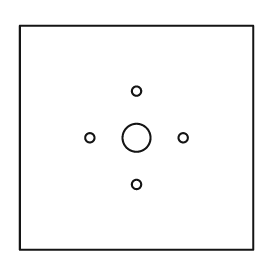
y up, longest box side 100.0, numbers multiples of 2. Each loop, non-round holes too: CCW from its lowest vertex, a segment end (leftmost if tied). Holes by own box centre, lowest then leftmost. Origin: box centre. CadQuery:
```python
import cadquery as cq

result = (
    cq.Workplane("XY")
    .moveTo(-50.0, -48.0)
    .lineTo(50.0, -48.0)
    .lineTo(50.0, 48.0)
    .lineTo(-50.0, 48.0)
    .close()
    .moveTo(0.0, -20.0)
    .circle(2.0)
    .moveTo(-20.0, 0.0)
    .circle(2.0)
    .moveTo(0.0, 0.0)
    .circle(6.0)
    .moveTo(20.0, 0.0)
    .circle(2.0)
    .moveTo(0.0, 20.0)
    .circle(2.0)
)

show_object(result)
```